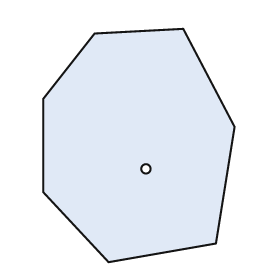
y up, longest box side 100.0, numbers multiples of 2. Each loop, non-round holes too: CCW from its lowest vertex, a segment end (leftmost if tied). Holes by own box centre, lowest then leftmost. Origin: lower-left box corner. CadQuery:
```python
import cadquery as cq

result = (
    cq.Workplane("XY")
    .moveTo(28.0, 0.0)
    .lineTo(74.0, 8.0)
    .lineTo(82.0, 58.0)
    .lineTo(60.0, 100.0)
    .lineTo(22.0, 98.0)
    .lineTo(0.0, 70.0)
    .lineTo(0.0, 30.0)
    .close()
    .moveTo(44.0, 40.0)
    .circle(2.0)
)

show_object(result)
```